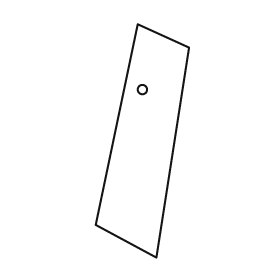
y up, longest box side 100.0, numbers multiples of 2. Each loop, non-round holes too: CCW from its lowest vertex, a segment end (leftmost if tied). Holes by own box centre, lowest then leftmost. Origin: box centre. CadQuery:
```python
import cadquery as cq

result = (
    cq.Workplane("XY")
    .moveTo(6.0, -50.0)
    .lineTo(20.0, 40.0)
    .lineTo(-2.0, 50.0)
    .lineTo(-20.0, -36.0)
    .close()
    .moveTo(0.0, 22.0)
    .circle(2.0)
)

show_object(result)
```